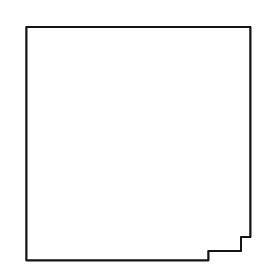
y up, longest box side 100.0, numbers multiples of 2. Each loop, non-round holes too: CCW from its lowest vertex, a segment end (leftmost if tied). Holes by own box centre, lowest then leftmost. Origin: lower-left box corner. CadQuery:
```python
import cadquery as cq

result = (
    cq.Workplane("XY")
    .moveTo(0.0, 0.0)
    .lineTo(78.0, 0.0)
    .lineTo(78.0, 4.0)
    .lineTo(92.0, 4.0)
    .lineTo(92.0, 10.0)
    .lineTo(96.0, 10.0)
    .lineTo(96.0, 100.0)
    .lineTo(0.0, 100.0)
    .close()
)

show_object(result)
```